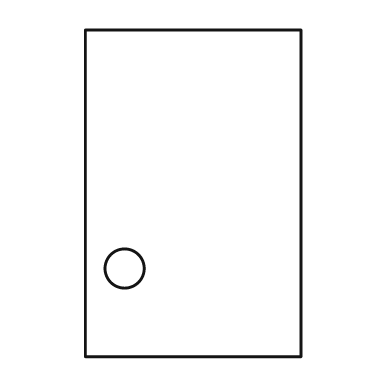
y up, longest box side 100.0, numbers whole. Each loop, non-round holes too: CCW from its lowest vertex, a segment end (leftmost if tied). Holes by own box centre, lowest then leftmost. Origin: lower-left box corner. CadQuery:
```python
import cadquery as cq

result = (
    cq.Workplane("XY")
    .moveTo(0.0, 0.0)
    .lineTo(66.0, 0.0)
    .lineTo(66.0, 100.0)
    .lineTo(0.0, 100.0)
    .close()
    .moveTo(12.0, 27.0)
    .circle(6.0)
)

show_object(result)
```